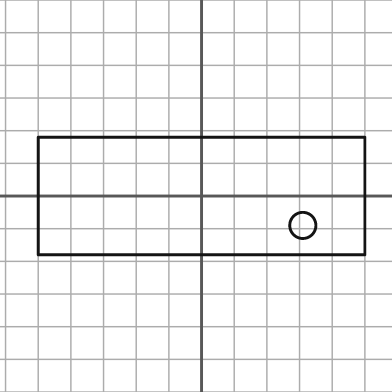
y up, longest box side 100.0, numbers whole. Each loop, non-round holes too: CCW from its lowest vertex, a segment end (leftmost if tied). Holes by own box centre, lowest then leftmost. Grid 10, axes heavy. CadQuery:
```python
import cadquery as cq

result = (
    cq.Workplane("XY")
    .moveTo(-50.0, -18.0)
    .lineTo(50.0, -18.0)
    .lineTo(50.0, 18.0)
    .lineTo(-50.0, 18.0)
    .close()
    .moveTo(31.0, -9.0)
    .circle(4.0)
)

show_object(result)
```